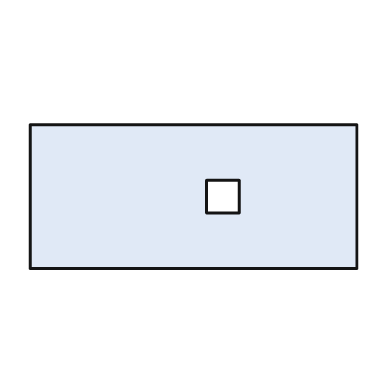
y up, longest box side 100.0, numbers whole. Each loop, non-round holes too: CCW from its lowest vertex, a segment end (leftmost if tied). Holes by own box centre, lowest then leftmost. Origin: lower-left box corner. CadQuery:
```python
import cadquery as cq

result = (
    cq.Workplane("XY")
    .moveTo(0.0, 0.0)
    .lineTo(100.0, 0.0)
    .lineTo(100.0, 44.0)
    .lineTo(0.0, 44.0)
    .close()
    .moveTo(54.0, 17.0)
    .lineTo(64.0, 17.0)
    .lineTo(64.0, 27.0)
    .lineTo(54.0, 27.0)
    .close()
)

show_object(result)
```